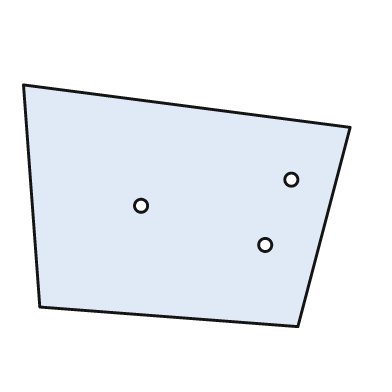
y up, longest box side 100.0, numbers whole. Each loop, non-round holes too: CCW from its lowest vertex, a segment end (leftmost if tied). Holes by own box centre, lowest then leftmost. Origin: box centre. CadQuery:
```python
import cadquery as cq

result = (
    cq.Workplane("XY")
    .moveTo(34.0, -37.0)
    .lineTo(50.0, 24.0)
    .lineTo(-50.0, 37.0)
    .lineTo(-45.0, -31.0)
    .close()
    .moveTo(24.0, -12.0)
    .circle(2.0)
    .moveTo(-14.0, 0.0)
    .circle(2.0)
    .moveTo(32.0, 8.0)
    .circle(2.0)
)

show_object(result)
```